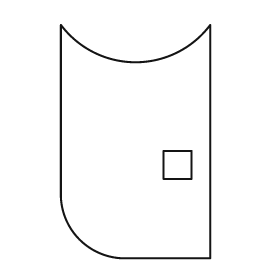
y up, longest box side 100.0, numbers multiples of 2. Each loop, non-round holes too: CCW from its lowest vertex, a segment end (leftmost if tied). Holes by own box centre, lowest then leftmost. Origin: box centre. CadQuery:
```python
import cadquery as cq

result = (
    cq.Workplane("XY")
    .moveTo(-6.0, -50.0)
    .lineTo(32.0, -50.0)
    .lineTo(32.0, 50.0)
    .threePointArc((0.0, 34.0), (-32.0, 50.0))
    .lineTo(-32.0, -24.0)
    .threePointArc((-24.0, -42.0), (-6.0, -50.0))
    .close()
    .moveTo(12.0, -16.0)
    .lineTo(24.0, -16.0)
    .lineTo(24.0, -4.0)
    .lineTo(12.0, -4.0)
    .close()
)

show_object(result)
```